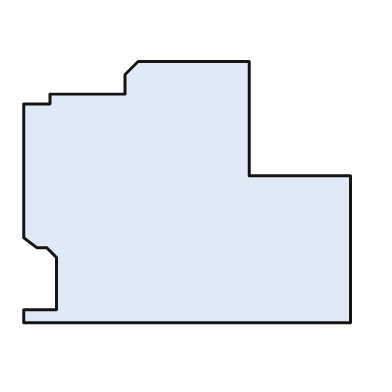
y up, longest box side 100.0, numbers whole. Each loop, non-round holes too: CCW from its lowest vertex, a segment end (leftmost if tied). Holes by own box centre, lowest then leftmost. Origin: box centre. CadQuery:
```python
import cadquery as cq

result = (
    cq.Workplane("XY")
    .moveTo(-50.0, -40.0)
    .lineTo(50.0, -40.0)
    .lineTo(50.0, 5.0)
    .lineTo(19.0, 5.0)
    .lineTo(19.0, 40.0)
    .lineTo(-15.0, 40.0)
    .lineTo(-19.0, 36.0)
    .lineTo(-19.0, 30.0)
    .lineTo(-42.0, 30.0)
    .lineTo(-42.0, 27.0)
    .lineTo(-50.0, 27.0)
    .lineTo(-50.0, -14.0)
    .lineTo(-46.0, -17.0)
    .lineTo(-43.0, -17.0)
    .lineTo(-40.0, -20.0)
    .lineTo(-40.0, -36.0)
    .lineTo(-50.0, -36.0)
    .close()
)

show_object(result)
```